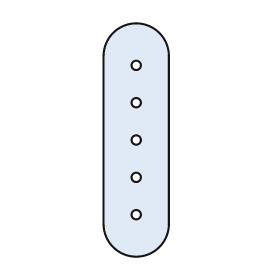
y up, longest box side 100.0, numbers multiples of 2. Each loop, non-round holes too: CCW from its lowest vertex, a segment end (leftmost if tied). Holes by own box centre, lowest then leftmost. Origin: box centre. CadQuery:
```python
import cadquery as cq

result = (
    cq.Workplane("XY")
    .moveTo(-14.0, -36.0)
    .threePointArc((0.0, -50.0), (14.0, -36.0))
    .lineTo(14.0, 36.0)
    .threePointArc((0.0, 50.0), (-14.0, 36.0))
    .close()
    .moveTo(0.0, -32.0)
    .circle(2.0)
    .moveTo(0.0, -16.0)
    .circle(2.0)
    .moveTo(0.0, 0.0)
    .circle(2.0)
    .moveTo(0.0, 16.0)
    .circle(2.0)
    .moveTo(0.0, 32.0)
    .circle(2.0)
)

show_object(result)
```